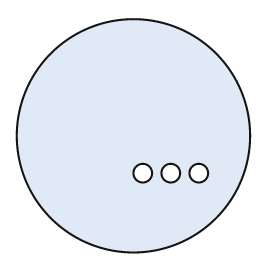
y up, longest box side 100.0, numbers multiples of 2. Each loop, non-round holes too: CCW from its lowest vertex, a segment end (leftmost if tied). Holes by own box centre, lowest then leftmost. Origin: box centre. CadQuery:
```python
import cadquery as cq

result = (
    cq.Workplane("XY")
    .moveTo(0.0, 0.0)
    .circle(50.0)
    .moveTo(4.0, -16.0)
    .circle(4.0)
    .moveTo(16.0, -16.0)
    .circle(4.0)
    .moveTo(28.0, -16.0)
    .circle(4.0)
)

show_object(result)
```